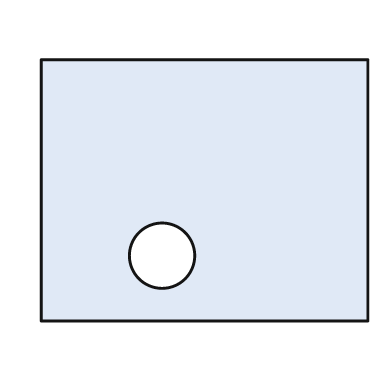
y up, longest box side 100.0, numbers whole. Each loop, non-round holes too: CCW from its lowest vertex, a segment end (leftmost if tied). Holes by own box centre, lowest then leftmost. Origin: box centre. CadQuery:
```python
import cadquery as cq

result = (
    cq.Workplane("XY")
    .moveTo(-50.0, -40.0)
    .lineTo(50.0, -40.0)
    .lineTo(50.0, 40.0)
    .lineTo(-50.0, 40.0)
    .close()
    .moveTo(-13.0, -20.0)
    .circle(10.0)
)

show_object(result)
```